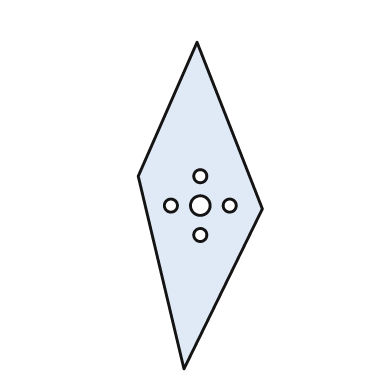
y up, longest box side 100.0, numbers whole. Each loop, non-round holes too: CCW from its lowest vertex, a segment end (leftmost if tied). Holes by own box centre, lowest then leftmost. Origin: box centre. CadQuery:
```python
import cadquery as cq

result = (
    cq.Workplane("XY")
    .moveTo(-5.0, -50.0)
    .lineTo(19.0, -1.0)
    .lineTo(-1.0, 50.0)
    .lineTo(-19.0, 9.0)
    .close()
    .moveTo(0.0, -9.0)
    .circle(2.0)
    .moveTo(-9.0, 0.0)
    .circle(2.0)
    .moveTo(0.0, 0.0)
    .circle(3.0)
    .moveTo(9.0, 0.0)
    .circle(2.0)
    .moveTo(0.0, 9.0)
    .circle(2.0)
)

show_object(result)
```